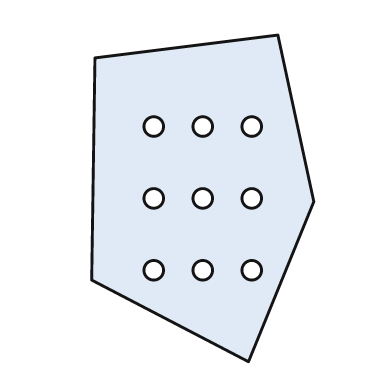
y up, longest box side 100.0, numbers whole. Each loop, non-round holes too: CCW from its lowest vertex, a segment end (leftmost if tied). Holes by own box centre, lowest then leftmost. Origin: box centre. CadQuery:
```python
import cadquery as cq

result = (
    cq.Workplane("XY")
    .moveTo(14.0, -50.0)
    .lineTo(34.0, -1.0)
    .lineTo(23.0, 50.0)
    .lineTo(-33.0, 43.0)
    .lineTo(-34.0, -25.0)
    .close()
    .moveTo(-15.0, -22.0)
    .circle(3.0)
    .moveTo(0.0, -22.0)
    .circle(3.0)
    .moveTo(15.0, -22.0)
    .circle(3.0)
    .moveTo(-15.0, 0.0)
    .circle(3.0)
    .moveTo(0.0, 0.0)
    .circle(3.0)
    .moveTo(15.0, 0.0)
    .circle(3.0)
    .moveTo(-15.0, 22.0)
    .circle(3.0)
    .moveTo(0.0, 22.0)
    .circle(3.0)
    .moveTo(15.0, 22.0)
    .circle(3.0)
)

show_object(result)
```